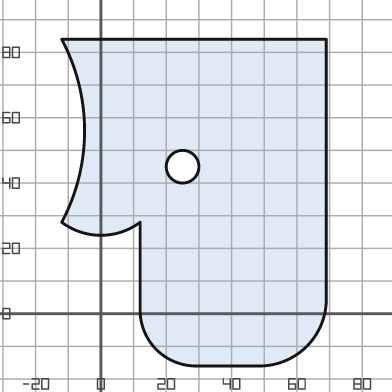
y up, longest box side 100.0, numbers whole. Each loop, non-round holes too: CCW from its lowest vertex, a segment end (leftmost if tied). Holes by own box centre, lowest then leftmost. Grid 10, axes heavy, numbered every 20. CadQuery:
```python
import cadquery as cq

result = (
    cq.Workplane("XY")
    .moveTo(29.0, -16.0)
    .lineTo(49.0, -16.0)
    .threePointArc((63.0, -10.0), (69.0, 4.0))
    .lineTo(69.0, 84.0)
    .lineTo(-12.0, 84.0)
    .threePointArc((-5.0, 56.0), (-12.0, 28.0))
    .threePointArc((0.0, 24.0), (12.0, 28.0))
    .lineTo(12.0, 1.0)
    .threePointArc((17.0, -11.0), (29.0, -16.0))
    .close()
    .moveTo(25.0, 45.0)
    .circle(5.0)
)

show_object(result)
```